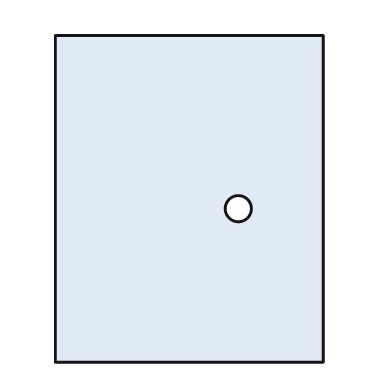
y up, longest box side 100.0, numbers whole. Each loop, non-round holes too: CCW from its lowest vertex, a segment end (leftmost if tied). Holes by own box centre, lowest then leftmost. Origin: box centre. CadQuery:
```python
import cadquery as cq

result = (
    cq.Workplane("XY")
    .moveTo(-41.0, -50.0)
    .lineTo(41.0, -50.0)
    .lineTo(41.0, 50.0)
    .lineTo(-41.0, 50.0)
    .close()
    .moveTo(15.0, -3.0)
    .circle(4.0)
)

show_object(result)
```